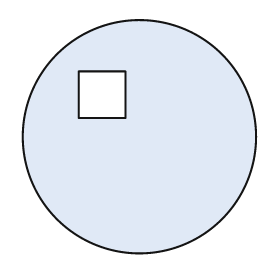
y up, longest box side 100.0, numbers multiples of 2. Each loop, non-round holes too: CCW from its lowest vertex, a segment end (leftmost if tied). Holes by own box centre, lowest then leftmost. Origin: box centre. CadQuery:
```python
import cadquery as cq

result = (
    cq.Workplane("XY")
    .moveTo(0.0, 0.0)
    .circle(50.0)
    .moveTo(-26.0, 8.0)
    .lineTo(-6.0, 8.0)
    .lineTo(-6.0, 28.0)
    .lineTo(-26.0, 28.0)
    .close()
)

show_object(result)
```